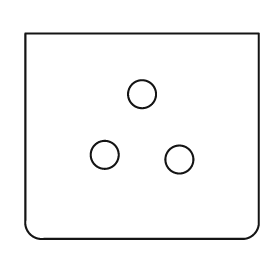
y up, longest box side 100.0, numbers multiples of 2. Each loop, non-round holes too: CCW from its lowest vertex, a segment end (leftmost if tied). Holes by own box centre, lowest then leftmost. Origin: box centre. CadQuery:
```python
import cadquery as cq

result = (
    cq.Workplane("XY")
    .moveTo(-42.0, -44.0)
    .lineTo(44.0, -44.0)
    .threePointArc((48.0, -42.0), (50.0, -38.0))
    .lineTo(50.0, 44.0)
    .lineTo(-50.0, 44.0)
    .lineTo(-50.0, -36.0)
    .threePointArc((-48.0, -42.0), (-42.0, -44.0))
    .close()
    .moveTo(16.0, -10.0)
    .circle(6.0)
    .moveTo(-16.0, -8.0)
    .circle(6.0)
    .moveTo(0.0, 18.0)
    .circle(6.0)
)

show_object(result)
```